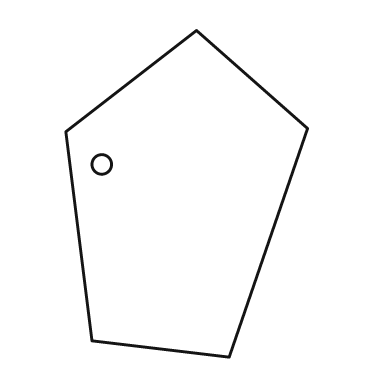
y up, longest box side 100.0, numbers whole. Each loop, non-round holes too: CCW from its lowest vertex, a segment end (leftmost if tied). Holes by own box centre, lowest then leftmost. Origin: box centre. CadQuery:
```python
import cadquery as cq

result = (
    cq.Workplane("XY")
    .moveTo(13.0, -50.0)
    .lineTo(37.0, 20.0)
    .lineTo(3.0, 50.0)
    .lineTo(-37.0, 19.0)
    .lineTo(-29.0, -45.0)
    .close()
    .moveTo(-26.0, 9.0)
    .circle(3.0)
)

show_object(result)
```